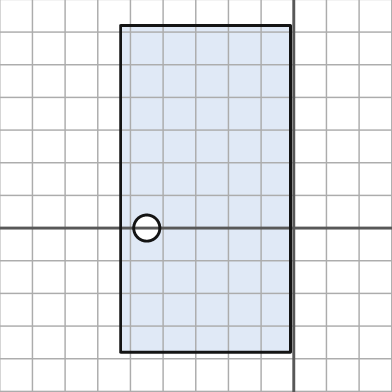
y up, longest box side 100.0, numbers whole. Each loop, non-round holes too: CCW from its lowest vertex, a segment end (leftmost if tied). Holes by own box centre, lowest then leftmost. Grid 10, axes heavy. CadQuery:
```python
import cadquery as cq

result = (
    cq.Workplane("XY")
    .moveTo(-53.0, -38.0)
    .lineTo(-1.0, -38.0)
    .lineTo(-1.0, 62.0)
    .lineTo(-53.0, 62.0)
    .close()
    .moveTo(-45.0, 0.0)
    .circle(4.0)
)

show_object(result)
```